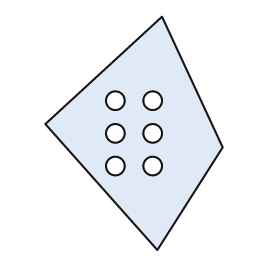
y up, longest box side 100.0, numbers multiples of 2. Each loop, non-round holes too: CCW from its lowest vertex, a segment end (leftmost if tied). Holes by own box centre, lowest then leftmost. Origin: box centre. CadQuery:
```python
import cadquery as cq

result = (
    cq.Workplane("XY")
    .moveTo(10.0, -50.0)
    .lineTo(38.0, -6.0)
    .lineTo(12.0, 50.0)
    .lineTo(-38.0, 4.0)
    .close()
    .moveTo(-8.0, -14.0)
    .circle(4.0)
    .moveTo(8.0, -14.0)
    .circle(4.0)
    .moveTo(-8.0, 0.0)
    .circle(4.0)
    .moveTo(8.0, 0.0)
    .circle(4.0)
    .moveTo(-8.0, 14.0)
    .circle(4.0)
    .moveTo(8.0, 14.0)
    .circle(4.0)
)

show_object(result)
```